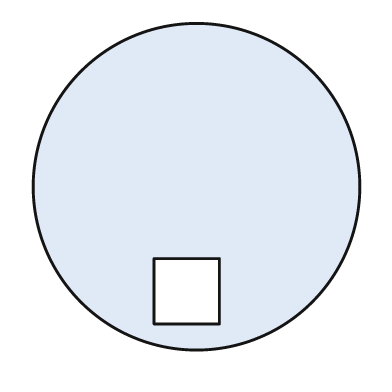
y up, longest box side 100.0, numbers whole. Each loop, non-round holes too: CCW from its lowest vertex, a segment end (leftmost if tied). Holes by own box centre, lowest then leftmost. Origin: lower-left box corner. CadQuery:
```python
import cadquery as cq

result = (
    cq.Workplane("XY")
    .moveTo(50.0, 50.0)
    .circle(50.0)
    .moveTo(37.0, 8.0)
    .lineTo(57.0, 8.0)
    .lineTo(57.0, 28.0)
    .lineTo(37.0, 28.0)
    .close()
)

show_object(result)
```